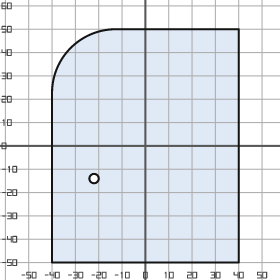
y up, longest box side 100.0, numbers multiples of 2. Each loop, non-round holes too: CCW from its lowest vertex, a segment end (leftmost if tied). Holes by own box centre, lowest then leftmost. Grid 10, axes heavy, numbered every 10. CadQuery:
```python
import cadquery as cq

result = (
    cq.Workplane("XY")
    .moveTo(-40.0, -50.0)
    .lineTo(40.0, -50.0)
    .lineTo(40.0, 50.0)
    .lineTo(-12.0, 50.0)
    .threePointArc((-32.0, 42.0), (-40.0, 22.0))
    .close()
    .moveTo(-22.0, -14.0)
    .circle(2.0)
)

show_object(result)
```